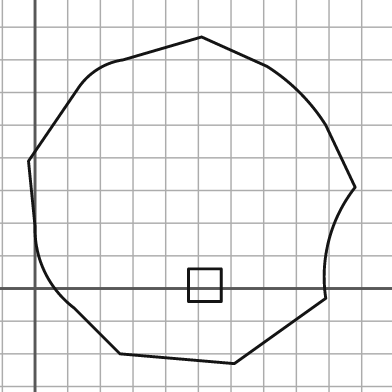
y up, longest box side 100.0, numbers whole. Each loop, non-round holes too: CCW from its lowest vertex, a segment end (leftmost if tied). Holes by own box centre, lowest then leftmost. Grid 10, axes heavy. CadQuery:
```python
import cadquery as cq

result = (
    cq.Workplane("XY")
    .moveTo(61.0, -23.0)
    .lineTo(89.0, -3.0)
    .threePointArc((90.0, 15.0), (98.0, 31.0))
    .lineTo(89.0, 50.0)
    .threePointArc((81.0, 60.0), (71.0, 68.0))
    .lineTo(51.0, 77.0)
    .lineTo(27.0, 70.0)
    .threePointArc((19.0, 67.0), (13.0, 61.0))
    .lineTo(-2.0, 39.0)
    .lineTo(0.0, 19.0)
    .threePointArc((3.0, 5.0), (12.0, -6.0))
    .lineTo(26.0, -20.0)
    .close()
    .moveTo(47.0, -4.0)
    .lineTo(57.0, -4.0)
    .lineTo(57.0, 6.0)
    .lineTo(47.0, 6.0)
    .close()
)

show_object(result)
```